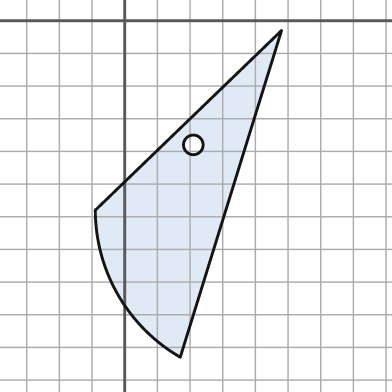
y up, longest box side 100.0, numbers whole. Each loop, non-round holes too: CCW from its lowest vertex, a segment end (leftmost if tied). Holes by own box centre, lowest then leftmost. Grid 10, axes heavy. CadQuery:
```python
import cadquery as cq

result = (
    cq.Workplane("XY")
    .moveTo(17.0, -103.0)
    .lineTo(48.0, -3.0)
    .lineTo(-9.0, -58.0)
    .threePointArc((-2.0, -84.0), (17.0, -103.0))
    .close()
    .moveTo(21.0, -38.0)
    .circle(3.0)
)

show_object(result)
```